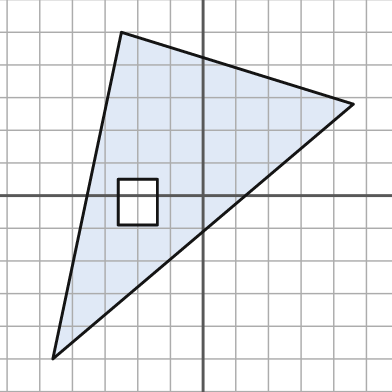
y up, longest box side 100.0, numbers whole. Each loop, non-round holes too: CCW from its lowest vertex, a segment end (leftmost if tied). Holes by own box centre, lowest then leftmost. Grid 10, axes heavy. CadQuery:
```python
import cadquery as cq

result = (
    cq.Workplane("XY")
    .moveTo(-46.0, -50.0)
    .lineTo(46.0, 28.0)
    .lineTo(-25.0, 50.0)
    .close()
    .moveTo(-26.0, -9.0)
    .lineTo(-14.0, -9.0)
    .lineTo(-14.0, 5.0)
    .lineTo(-26.0, 5.0)
    .close()
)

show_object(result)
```